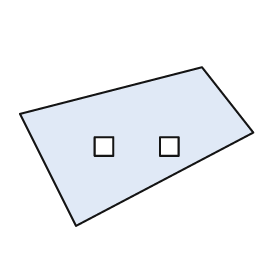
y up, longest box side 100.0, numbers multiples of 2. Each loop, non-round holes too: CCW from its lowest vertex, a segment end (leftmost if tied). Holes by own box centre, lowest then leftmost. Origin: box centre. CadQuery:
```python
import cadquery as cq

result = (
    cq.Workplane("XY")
    .moveTo(-26.0, -34.0)
    .lineTo(50.0, 6.0)
    .lineTo(28.0, 34.0)
    .lineTo(-50.0, 14.0)
    .close()
    .moveTo(-18.0, -4.0)
    .lineTo(-10.0, -4.0)
    .lineTo(-10.0, 4.0)
    .lineTo(-18.0, 4.0)
    .close()
    .moveTo(10.0, -4.0)
    .lineTo(18.0, -4.0)
    .lineTo(18.0, 4.0)
    .lineTo(10.0, 4.0)
    .close()
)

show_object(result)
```